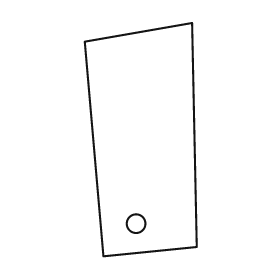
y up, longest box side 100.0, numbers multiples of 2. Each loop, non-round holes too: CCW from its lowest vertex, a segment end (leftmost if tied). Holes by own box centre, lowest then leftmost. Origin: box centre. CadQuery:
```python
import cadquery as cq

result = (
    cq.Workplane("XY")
    .moveTo(-16.0, -50.0)
    .lineTo(24.0, -46.0)
    .lineTo(22.0, 50.0)
    .lineTo(-24.0, 42.0)
    .close()
    .moveTo(-2.0, -36.0)
    .circle(4.0)
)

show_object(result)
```